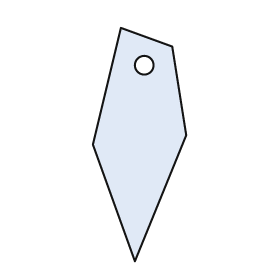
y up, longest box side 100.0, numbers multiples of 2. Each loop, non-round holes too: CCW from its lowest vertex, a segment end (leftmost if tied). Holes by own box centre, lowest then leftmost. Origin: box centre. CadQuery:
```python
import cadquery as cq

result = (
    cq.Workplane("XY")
    .moveTo(-2.0, -50.0)
    .lineTo(20.0, 4.0)
    .lineTo(14.0, 42.0)
    .lineTo(-8.0, 50.0)
    .lineTo(-20.0, 0.0)
    .close()
    .moveTo(2.0, 34.0)
    .circle(4.0)
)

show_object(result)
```